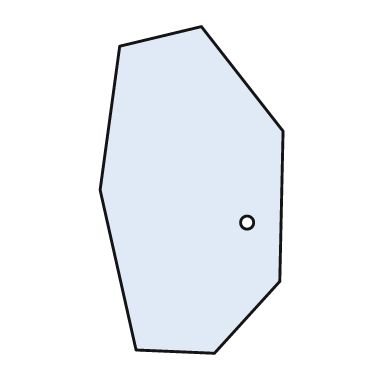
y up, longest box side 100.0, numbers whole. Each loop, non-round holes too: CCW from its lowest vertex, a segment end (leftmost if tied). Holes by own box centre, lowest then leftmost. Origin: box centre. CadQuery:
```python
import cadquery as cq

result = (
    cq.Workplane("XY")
    .moveTo(7.0, -50.0)
    .lineTo(27.0, -28.0)
    .lineTo(28.0, 18.0)
    .lineTo(3.0, 50.0)
    .lineTo(-22.0, 44.0)
    .lineTo(-28.0, 0.0)
    .lineTo(-17.0, -49.0)
    .close()
    .moveTo(17.0, -10.0)
    .circle(2.0)
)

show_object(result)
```